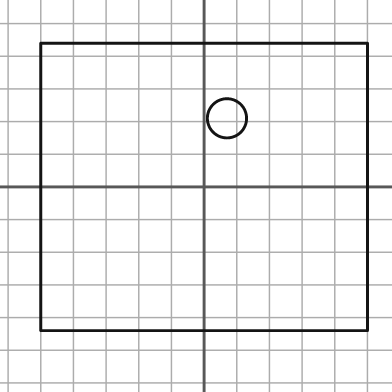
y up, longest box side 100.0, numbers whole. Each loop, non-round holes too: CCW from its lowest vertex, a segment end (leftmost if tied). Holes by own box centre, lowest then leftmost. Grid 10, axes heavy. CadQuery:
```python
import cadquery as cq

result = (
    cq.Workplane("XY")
    .moveTo(-50.0, -44.0)
    .lineTo(50.0, -44.0)
    .lineTo(50.0, 44.0)
    .lineTo(-50.0, 44.0)
    .close()
    .moveTo(7.0, 21.0)
    .circle(6.0)
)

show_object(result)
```